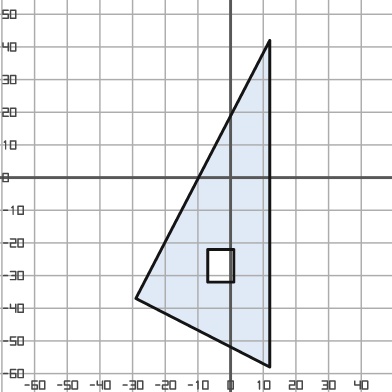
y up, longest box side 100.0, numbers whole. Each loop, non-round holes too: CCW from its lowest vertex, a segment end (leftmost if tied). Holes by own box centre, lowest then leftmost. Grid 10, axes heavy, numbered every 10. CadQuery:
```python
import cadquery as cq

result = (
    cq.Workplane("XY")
    .moveTo(12.0, -58.0)
    .lineTo(12.0, 42.0)
    .lineTo(-29.0, -37.0)
    .close()
    .moveTo(-7.0, -32.0)
    .lineTo(1.0, -32.0)
    .lineTo(1.0, -22.0)
    .lineTo(-7.0, -22.0)
    .close()
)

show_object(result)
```